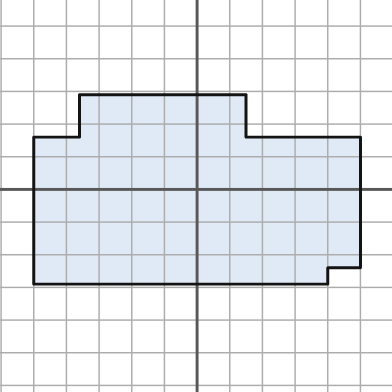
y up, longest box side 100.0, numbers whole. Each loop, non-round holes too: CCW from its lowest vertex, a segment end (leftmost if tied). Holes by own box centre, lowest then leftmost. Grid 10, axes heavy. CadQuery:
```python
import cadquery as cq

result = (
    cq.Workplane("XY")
    .moveTo(-50.0, -29.0)
    .lineTo(40.0, -29.0)
    .lineTo(40.0, -24.0)
    .lineTo(50.0, -24.0)
    .lineTo(50.0, 16.0)
    .lineTo(15.0, 16.0)
    .lineTo(15.0, 29.0)
    .lineTo(-36.0, 29.0)
    .lineTo(-36.0, 16.0)
    .lineTo(-50.0, 16.0)
    .close()
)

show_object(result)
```